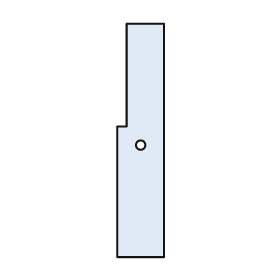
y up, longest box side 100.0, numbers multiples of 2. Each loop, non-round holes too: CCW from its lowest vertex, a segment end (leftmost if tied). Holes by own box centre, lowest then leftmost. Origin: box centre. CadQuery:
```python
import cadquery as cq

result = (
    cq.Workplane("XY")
    .moveTo(-10.0, -50.0)
    .lineTo(10.0, -50.0)
    .lineTo(10.0, 50.0)
    .lineTo(-6.0, 50.0)
    .lineTo(-6.0, 6.0)
    .lineTo(-10.0, 6.0)
    .close()
    .moveTo(0.0, -2.0)
    .circle(2.0)
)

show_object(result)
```